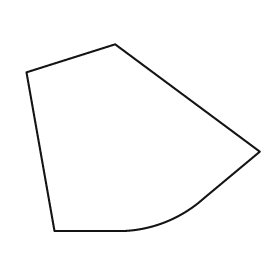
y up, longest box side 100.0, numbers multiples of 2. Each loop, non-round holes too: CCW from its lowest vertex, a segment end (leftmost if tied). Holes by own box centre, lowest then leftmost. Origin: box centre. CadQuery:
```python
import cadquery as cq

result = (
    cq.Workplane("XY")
    .moveTo(-38.0, -40.0)
    .lineTo(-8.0, -40.0)
    .threePointArc((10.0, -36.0), (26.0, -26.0))
    .lineTo(50.0, -6.0)
    .lineTo(-12.0, 40.0)
    .lineTo(-50.0, 28.0)
    .close()
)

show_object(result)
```